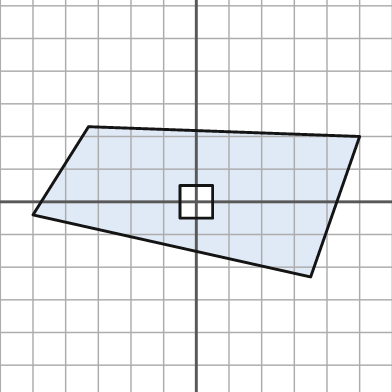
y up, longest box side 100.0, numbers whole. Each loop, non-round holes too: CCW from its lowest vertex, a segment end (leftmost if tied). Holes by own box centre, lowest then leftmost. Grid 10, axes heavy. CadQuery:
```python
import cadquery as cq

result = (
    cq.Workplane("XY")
    .moveTo(35.0, -23.0)
    .lineTo(50.0, 20.0)
    .lineTo(-33.0, 23.0)
    .lineTo(-50.0, -4.0)
    .close()
    .moveTo(-5.0, -5.0)
    .lineTo(5.0, -5.0)
    .lineTo(5.0, 5.0)
    .lineTo(-5.0, 5.0)
    .close()
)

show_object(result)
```